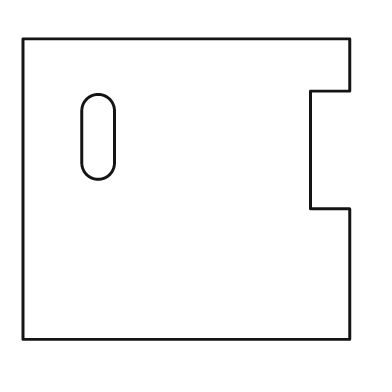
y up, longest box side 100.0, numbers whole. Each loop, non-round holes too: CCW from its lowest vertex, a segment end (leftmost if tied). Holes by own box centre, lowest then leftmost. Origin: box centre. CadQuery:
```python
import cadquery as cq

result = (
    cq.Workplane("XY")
    .moveTo(-50.0, -46.0)
    .lineTo(50.0, -46.0)
    .lineTo(50.0, -6.0)
    .lineTo(38.0, -6.0)
    .lineTo(38.0, 30.0)
    .lineTo(50.0, 30.0)
    .lineTo(50.0, 46.0)
    .lineTo(-50.0, 46.0)
    .close()
    .moveTo(-32.0, 8.0)
    .threePointArc((-27.0, 3.0), (-22.0, 8.0))
    .lineTo(-22.0, 24.0)
    .threePointArc((-27.0, 29.0), (-32.0, 24.0))
    .close()
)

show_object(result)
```